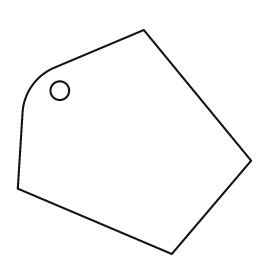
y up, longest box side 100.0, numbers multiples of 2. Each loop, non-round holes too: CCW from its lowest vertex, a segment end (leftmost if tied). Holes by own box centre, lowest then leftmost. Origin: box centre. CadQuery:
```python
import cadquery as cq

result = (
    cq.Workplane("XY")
    .moveTo(16.0, -48.0)
    .lineTo(50.0, -8.0)
    .lineTo(4.0, 48.0)
    .lineTo(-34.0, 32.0)
    .threePointArc((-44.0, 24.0), (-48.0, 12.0))
    .lineTo(-50.0, -20.0)
    .close()
    .moveTo(-32.0, 22.0)
    .circle(4.0)
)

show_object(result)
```